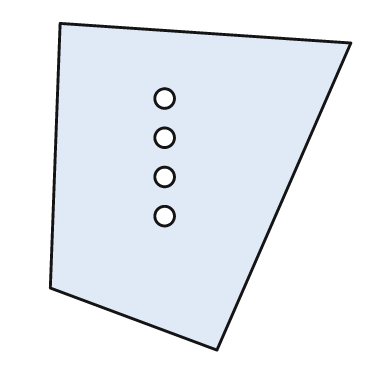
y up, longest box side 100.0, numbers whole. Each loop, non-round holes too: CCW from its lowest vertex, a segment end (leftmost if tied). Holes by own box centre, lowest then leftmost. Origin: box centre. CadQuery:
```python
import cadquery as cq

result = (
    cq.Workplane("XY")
    .moveTo(5.0, -50.0)
    .lineTo(46.0, 44.0)
    .lineTo(-43.0, 50.0)
    .lineTo(-46.0, -31.0)
    .close()
    .moveTo(-11.0, -9.0)
    .circle(3.0)
    .moveTo(-11.0, 3.0)
    .circle(3.0)
    .moveTo(-11.0, 15.0)
    .circle(3.0)
    .moveTo(-11.0, 27.0)
    .circle(3.0)
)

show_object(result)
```